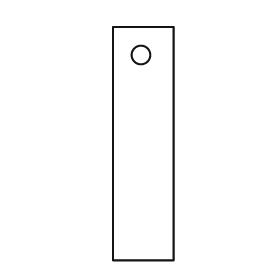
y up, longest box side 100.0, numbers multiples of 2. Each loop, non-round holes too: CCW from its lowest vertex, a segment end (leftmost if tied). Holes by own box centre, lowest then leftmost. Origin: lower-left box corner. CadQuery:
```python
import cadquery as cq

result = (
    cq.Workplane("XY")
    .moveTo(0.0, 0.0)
    .lineTo(26.0, 0.0)
    .lineTo(26.0, 100.0)
    .lineTo(0.0, 100.0)
    .close()
    .moveTo(12.0, 88.0)
    .circle(4.0)
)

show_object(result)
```